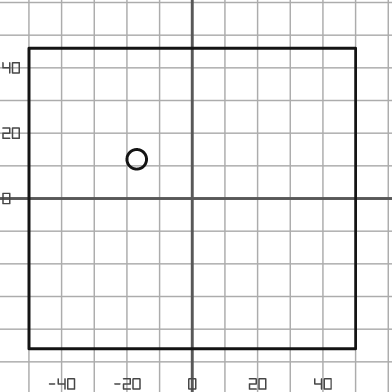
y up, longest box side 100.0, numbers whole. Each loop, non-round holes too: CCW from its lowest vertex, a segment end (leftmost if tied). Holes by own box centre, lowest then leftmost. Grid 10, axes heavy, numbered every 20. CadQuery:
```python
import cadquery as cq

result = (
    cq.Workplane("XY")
    .moveTo(-50.0, -46.0)
    .lineTo(50.0, -46.0)
    .lineTo(50.0, 46.0)
    .lineTo(-50.0, 46.0)
    .close()
    .moveTo(-17.0, 12.0)
    .circle(3.0)
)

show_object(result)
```